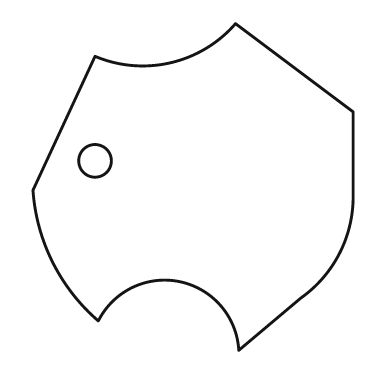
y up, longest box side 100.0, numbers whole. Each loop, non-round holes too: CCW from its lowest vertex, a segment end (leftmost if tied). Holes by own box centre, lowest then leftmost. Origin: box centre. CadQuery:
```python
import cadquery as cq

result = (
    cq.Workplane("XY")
    .moveTo(14.0, -50.0)
    .lineTo(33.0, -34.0)
    .threePointArc((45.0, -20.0), (49.0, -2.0))
    .lineTo(49.0, 23.0)
    .lineTo(13.0, 50.0)
    .threePointArc((-7.0, 38.0), (-30.0, 40.0))
    .lineTo(-49.0, -1.0)
    .threePointArc((-43.0, -23.0), (-29.0, -41.0))
    .threePointArc((-4.0, -29.0), (14.0, -50.0))
    .close()
    .moveTo(-30.0, 8.0)
    .circle(5.0)
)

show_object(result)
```